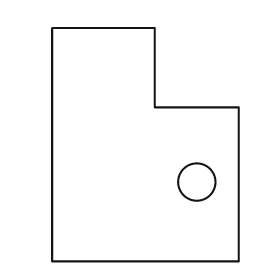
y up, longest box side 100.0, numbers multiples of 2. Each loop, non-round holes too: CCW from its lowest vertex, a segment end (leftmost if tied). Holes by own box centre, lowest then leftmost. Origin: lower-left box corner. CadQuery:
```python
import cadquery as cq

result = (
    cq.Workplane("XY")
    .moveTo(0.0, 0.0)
    .lineTo(80.0, 0.0)
    .lineTo(80.0, 66.0)
    .lineTo(44.0, 66.0)
    .lineTo(44.0, 100.0)
    .lineTo(0.0, 100.0)
    .close()
    .moveTo(62.0, 34.0)
    .circle(8.0)
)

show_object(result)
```